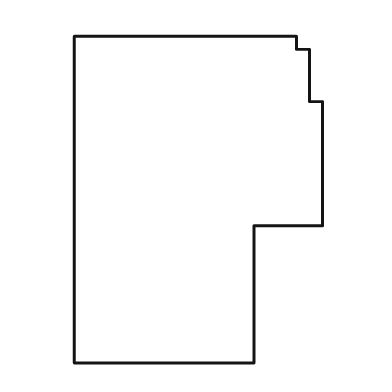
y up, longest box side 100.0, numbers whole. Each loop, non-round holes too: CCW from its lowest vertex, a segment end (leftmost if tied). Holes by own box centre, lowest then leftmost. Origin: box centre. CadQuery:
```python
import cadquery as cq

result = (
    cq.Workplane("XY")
    .moveTo(-38.0, -50.0)
    .lineTo(17.0, -50.0)
    .lineTo(17.0, -8.0)
    .lineTo(38.0, -8.0)
    .lineTo(38.0, 30.0)
    .lineTo(34.0, 30.0)
    .lineTo(34.0, 46.0)
    .lineTo(30.0, 46.0)
    .lineTo(30.0, 50.0)
    .lineTo(-38.0, 50.0)
    .close()
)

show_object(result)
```